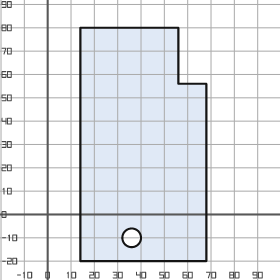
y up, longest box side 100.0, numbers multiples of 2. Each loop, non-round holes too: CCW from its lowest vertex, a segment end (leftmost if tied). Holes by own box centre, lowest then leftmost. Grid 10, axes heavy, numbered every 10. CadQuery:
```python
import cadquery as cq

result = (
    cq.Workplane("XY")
    .moveTo(14.0, -20.0)
    .lineTo(68.0, -20.0)
    .lineTo(68.0, 56.0)
    .lineTo(56.0, 56.0)
    .lineTo(56.0, 80.0)
    .lineTo(14.0, 80.0)
    .close()
    .moveTo(36.0, -10.0)
    .circle(4.0)
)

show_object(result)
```